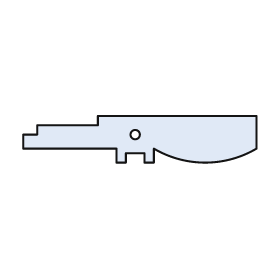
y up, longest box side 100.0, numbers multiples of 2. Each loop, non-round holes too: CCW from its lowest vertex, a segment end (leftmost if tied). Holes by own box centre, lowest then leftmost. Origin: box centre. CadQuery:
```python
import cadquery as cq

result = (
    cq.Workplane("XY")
    .moveTo(-10.0, -10.0)
    .lineTo(-6.0, -10.0)
    .lineTo(-6.0, -6.0)
    .lineTo(2.0, -6.0)
    .lineTo(2.0, -10.0)
    .lineTo(6.0, -10.0)
    .lineTo(6.0, -4.0)
    .threePointArc((28.0, -10.0), (50.0, -4.0))
    .lineTo(50.0, 10.0)
    .lineTo(-18.0, 10.0)
    .lineTo(-18.0, 6.0)
    .lineTo(-44.0, 6.0)
    .lineTo(-44.0, 2.0)
    .lineTo(-50.0, 2.0)
    .lineTo(-50.0, -4.0)
    .lineTo(-10.0, -4.0)
    .close()
    .moveTo(-2.0, 2.0)
    .circle(2.0)
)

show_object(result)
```